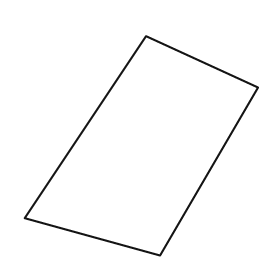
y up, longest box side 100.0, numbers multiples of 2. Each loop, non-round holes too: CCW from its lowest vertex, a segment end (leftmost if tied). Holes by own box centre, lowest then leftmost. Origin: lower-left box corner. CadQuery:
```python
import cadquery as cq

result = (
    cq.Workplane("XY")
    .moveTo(58.0, 0.0)
    .lineTo(100.0, 72.0)
    .lineTo(52.0, 94.0)
    .lineTo(0.0, 16.0)
    .close()
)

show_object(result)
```